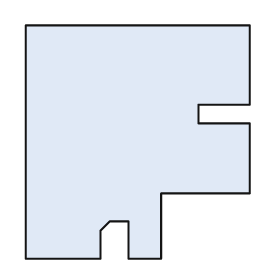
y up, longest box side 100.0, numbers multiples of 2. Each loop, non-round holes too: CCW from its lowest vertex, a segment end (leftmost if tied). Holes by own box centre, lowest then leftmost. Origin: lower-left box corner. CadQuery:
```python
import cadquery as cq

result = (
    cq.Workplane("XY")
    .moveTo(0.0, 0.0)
    .lineTo(32.0, 0.0)
    .lineTo(32.0, 12.0)
    .lineTo(36.0, 16.0)
    .lineTo(44.0, 16.0)
    .lineTo(44.0, 0.0)
    .lineTo(58.0, 0.0)
    .lineTo(58.0, 28.0)
    .lineTo(96.0, 28.0)
    .lineTo(96.0, 58.0)
    .lineTo(74.0, 58.0)
    .lineTo(74.0, 66.0)
    .lineTo(96.0, 66.0)
    .lineTo(96.0, 100.0)
    .lineTo(0.0, 100.0)
    .close()
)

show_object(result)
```